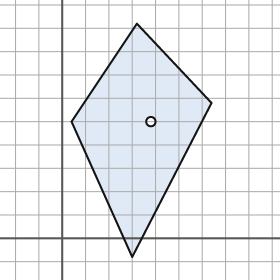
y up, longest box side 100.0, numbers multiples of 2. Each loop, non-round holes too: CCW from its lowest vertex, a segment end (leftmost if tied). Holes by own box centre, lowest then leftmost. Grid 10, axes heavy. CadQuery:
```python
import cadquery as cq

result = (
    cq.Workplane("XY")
    .moveTo(30.0, -8.0)
    .lineTo(64.0, 58.0)
    .lineTo(32.0, 92.0)
    .lineTo(4.0, 50.0)
    .close()
    .moveTo(38.0, 50.0)
    .circle(2.0)
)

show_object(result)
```